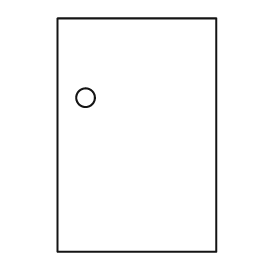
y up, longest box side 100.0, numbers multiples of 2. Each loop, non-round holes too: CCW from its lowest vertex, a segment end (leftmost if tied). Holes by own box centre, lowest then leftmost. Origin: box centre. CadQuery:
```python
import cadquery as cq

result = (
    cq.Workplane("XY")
    .moveTo(-34.0, -50.0)
    .lineTo(34.0, -50.0)
    .lineTo(34.0, 50.0)
    .lineTo(-34.0, 50.0)
    .close()
    .moveTo(-22.0, 16.0)
    .circle(4.0)
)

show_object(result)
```